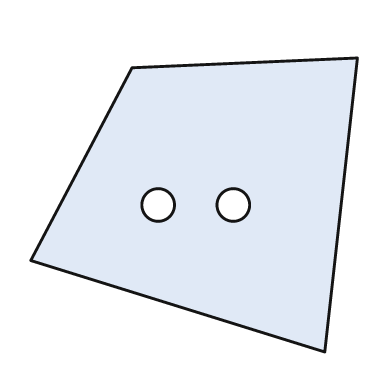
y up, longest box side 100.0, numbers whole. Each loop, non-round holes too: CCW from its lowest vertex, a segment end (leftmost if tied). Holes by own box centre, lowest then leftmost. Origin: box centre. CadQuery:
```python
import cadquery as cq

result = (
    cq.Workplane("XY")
    .moveTo(40.0, -45.0)
    .lineTo(50.0, 45.0)
    .lineTo(-19.0, 42.0)
    .lineTo(-50.0, -17.0)
    .close()
    .moveTo(-11.0, 0.0)
    .circle(5.0)
    .moveTo(12.0, 0.0)
    .circle(5.0)
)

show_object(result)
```